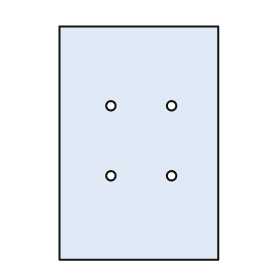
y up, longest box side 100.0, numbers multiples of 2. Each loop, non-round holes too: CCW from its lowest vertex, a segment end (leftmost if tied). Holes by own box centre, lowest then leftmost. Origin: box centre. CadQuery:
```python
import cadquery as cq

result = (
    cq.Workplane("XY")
    .moveTo(-34.0, -50.0)
    .lineTo(34.0, -50.0)
    .lineTo(34.0, 50.0)
    .lineTo(-34.0, 50.0)
    .close()
    .moveTo(-12.0, -14.0)
    .circle(2.0)
    .moveTo(14.0, -14.0)
    .circle(2.0)
    .moveTo(-12.0, 16.0)
    .circle(2.0)
    .moveTo(14.0, 16.0)
    .circle(2.0)
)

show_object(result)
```